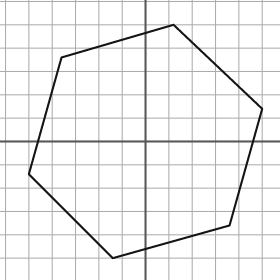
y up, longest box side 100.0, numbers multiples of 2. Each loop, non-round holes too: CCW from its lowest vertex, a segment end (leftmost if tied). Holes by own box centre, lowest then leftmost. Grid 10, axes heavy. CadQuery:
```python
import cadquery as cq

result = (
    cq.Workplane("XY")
    .moveTo(-14.0, -50.0)
    .lineTo(36.0, -36.0)
    .lineTo(50.0, 14.0)
    .lineTo(12.0, 50.0)
    .lineTo(-36.0, 36.0)
    .lineTo(-50.0, -14.0)
    .close()
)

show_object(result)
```